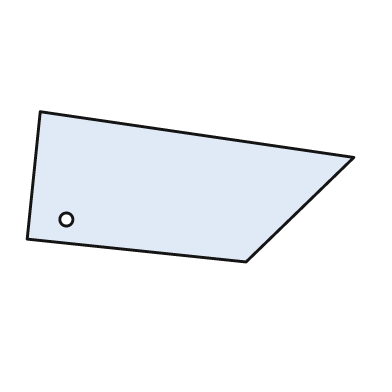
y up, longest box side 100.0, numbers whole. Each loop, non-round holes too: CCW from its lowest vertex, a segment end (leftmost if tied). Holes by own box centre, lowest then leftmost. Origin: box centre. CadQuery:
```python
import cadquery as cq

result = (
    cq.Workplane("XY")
    .moveTo(17.0, -23.0)
    .lineTo(50.0, 9.0)
    .lineTo(-46.0, 23.0)
    .lineTo(-50.0, -16.0)
    .close()
    .moveTo(-38.0, -10.0)
    .circle(2.0)
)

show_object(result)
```